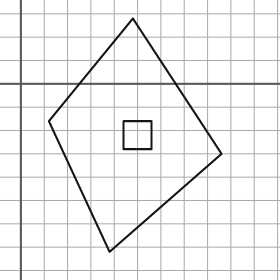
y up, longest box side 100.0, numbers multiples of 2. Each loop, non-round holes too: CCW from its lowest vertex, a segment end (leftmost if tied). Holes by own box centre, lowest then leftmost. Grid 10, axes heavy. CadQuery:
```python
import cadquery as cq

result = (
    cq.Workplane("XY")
    .moveTo(38.0, -72.0)
    .lineTo(86.0, -30.0)
    .lineTo(48.0, 28.0)
    .lineTo(12.0, -16.0)
    .close()
    .moveTo(44.0, -28.0)
    .lineTo(56.0, -28.0)
    .lineTo(56.0, -16.0)
    .lineTo(44.0, -16.0)
    .close()
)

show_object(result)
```